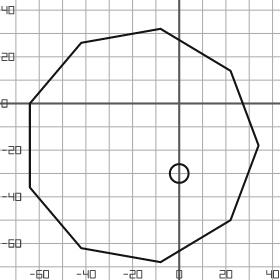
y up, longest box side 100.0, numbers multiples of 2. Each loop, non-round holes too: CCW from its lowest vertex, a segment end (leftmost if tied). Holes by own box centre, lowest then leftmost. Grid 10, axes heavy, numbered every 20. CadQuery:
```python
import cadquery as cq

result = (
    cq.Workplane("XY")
    .moveTo(-8.0, -68.0)
    .lineTo(22.0, -50.0)
    .lineTo(34.0, -18.0)
    .lineTo(22.0, 14.0)
    .lineTo(-8.0, 32.0)
    .lineTo(-42.0, 26.0)
    .lineTo(-64.0, 0.0)
    .lineTo(-64.0, -36.0)
    .lineTo(-42.0, -62.0)
    .close()
    .moveTo(0.0, -30.0)
    .circle(4.0)
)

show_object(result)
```